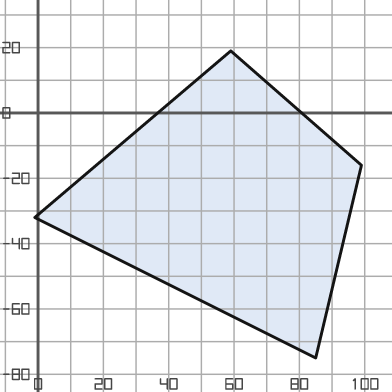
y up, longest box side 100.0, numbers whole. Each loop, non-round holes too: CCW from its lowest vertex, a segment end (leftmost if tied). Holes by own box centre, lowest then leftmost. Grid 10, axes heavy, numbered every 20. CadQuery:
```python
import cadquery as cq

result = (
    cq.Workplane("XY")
    .moveTo(85.0, -75.0)
    .lineTo(99.0, -16.0)
    .lineTo(59.0, 19.0)
    .lineTo(-1.0, -32.0)
    .close()
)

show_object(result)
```